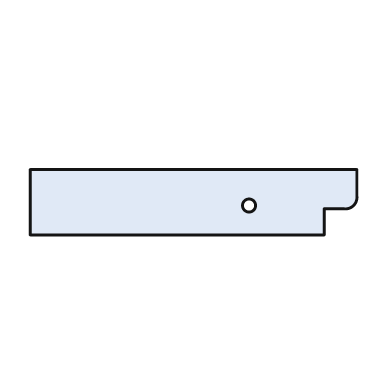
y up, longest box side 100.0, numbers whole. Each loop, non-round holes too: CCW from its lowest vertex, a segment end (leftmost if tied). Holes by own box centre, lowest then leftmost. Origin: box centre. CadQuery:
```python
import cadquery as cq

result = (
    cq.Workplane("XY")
    .moveTo(-50.0, -10.0)
    .lineTo(40.0, -10.0)
    .lineTo(40.0, -2.0)
    .lineTo(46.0, -2.0)
    .threePointArc((49.0, -1.0), (50.0, 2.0))
    .lineTo(50.0, 10.0)
    .lineTo(-50.0, 10.0)
    .close()
    .moveTo(17.0, -1.0)
    .circle(2.0)
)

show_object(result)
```